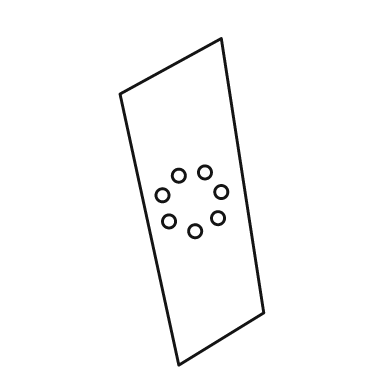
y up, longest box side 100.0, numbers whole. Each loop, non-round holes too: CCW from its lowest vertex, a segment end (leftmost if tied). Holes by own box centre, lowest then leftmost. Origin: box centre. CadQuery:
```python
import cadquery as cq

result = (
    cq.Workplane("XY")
    .moveTo(-4.0, -50.0)
    .lineTo(22.0, -34.0)
    .lineTo(9.0, 50.0)
    .lineTo(-22.0, 33.0)
    .close()
    .moveTo(1.0, -9.0)
    .circle(2.0)
    .moveTo(-7.0, -6.0)
    .circle(2.0)
    .moveTo(8.0, -5.0)
    .circle(2.0)
    .moveTo(-9.0, 2.0)
    .circle(2.0)
    .moveTo(9.0, 3.0)
    .circle(2.0)
    .moveTo(-4.0, 8.0)
    .circle(2.0)
    .moveTo(4.0, 9.0)
    .circle(2.0)
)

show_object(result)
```